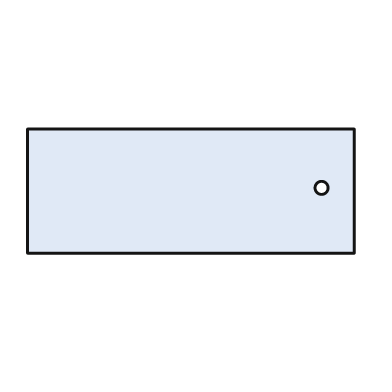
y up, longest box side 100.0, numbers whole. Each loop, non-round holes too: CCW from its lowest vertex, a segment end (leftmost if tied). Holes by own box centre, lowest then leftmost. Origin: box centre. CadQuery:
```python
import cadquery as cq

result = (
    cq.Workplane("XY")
    .moveTo(-50.0, -19.0)
    .lineTo(50.0, -19.0)
    .lineTo(50.0, 19.0)
    .lineTo(-50.0, 19.0)
    .close()
    .moveTo(40.0, 1.0)
    .circle(2.0)
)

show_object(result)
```